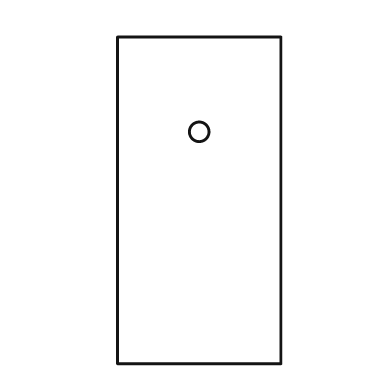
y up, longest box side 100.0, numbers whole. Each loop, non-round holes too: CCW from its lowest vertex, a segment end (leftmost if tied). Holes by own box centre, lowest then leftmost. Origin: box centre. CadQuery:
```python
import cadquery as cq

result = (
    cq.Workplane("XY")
    .moveTo(-25.0, -50.0)
    .lineTo(25.0, -50.0)
    .lineTo(25.0, 50.0)
    .lineTo(-25.0, 50.0)
    .close()
    .moveTo(0.0, 21.0)
    .circle(3.0)
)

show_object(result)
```